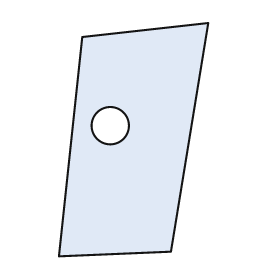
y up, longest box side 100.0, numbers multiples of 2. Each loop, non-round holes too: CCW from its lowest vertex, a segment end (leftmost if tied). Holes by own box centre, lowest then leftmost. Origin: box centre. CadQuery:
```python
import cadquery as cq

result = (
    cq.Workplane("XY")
    .moveTo(-32.0, -50.0)
    .lineTo(16.0, -48.0)
    .lineTo(32.0, 50.0)
    .lineTo(-22.0, 44.0)
    .close()
    .moveTo(-10.0, 6.0)
    .circle(8.0)
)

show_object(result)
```